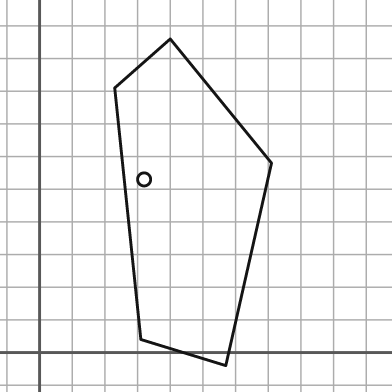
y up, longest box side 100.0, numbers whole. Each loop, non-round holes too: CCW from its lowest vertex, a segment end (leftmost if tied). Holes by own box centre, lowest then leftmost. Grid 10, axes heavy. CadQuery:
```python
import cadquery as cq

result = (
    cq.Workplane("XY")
    .moveTo(57.0, -4.0)
    .lineTo(71.0, 58.0)
    .lineTo(40.0, 96.0)
    .lineTo(23.0, 81.0)
    .lineTo(31.0, 4.0)
    .close()
    .moveTo(32.0, 53.0)
    .circle(2.0)
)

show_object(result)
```